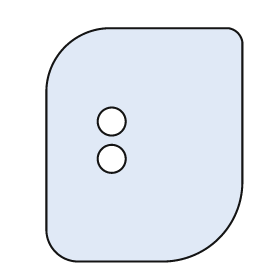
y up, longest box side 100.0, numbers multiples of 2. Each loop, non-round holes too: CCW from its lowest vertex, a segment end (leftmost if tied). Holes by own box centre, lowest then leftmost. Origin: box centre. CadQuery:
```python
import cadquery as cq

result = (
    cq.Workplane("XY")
    .moveTo(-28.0, -50.0)
    .lineTo(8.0, -50.0)
    .threePointArc((32.0, -40.0), (42.0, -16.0))
    .lineTo(42.0, 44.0)
    .threePointArc((40.0, 48.0), (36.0, 50.0))
    .lineTo(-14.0, 50.0)
    .threePointArc((-34.0, 42.0), (-42.0, 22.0))
    .lineTo(-42.0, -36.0)
    .threePointArc((-38.0, -46.0), (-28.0, -50.0))
    .close()
    .moveTo(-14.0, -6.0)
    .circle(6.0)
    .moveTo(-14.0, 10.0)
    .circle(6.0)
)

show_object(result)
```